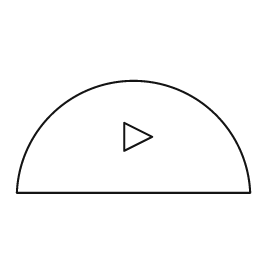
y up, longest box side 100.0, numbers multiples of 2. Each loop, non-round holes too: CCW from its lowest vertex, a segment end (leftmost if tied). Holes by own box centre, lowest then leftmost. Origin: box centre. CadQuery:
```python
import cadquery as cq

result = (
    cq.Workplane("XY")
    .moveTo(-50.0, -24.0)
    .lineTo(50.0, -24.0)
    .threePointArc((0.0, 24.0), (-50.0, -24.0))
    .close()
    .moveTo(-4.0, -6.0)
    .lineTo(8.0, 0.0)
    .lineTo(-4.0, 6.0)
    .close()
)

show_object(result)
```